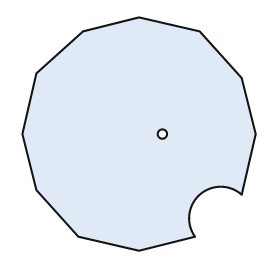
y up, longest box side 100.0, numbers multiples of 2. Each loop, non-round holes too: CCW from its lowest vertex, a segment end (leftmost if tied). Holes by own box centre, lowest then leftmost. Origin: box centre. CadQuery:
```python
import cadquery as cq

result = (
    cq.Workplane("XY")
    .moveTo(0.0, -50.0)
    .lineTo(24.0, -44.0)
    .threePointArc((26.0, -26.0), (44.0, -26.0))
    .lineTo(50.0, 0.0)
    .lineTo(44.0, 24.0)
    .lineTo(26.0, 44.0)
    .lineTo(0.0, 50.0)
    .lineTo(-24.0, 44.0)
    .lineTo(-44.0, 26.0)
    .lineTo(-50.0, 0.0)
    .lineTo(-44.0, -24.0)
    .lineTo(-26.0, -44.0)
    .close()
    .moveTo(10.0, 0.0)
    .circle(2.0)
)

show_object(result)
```